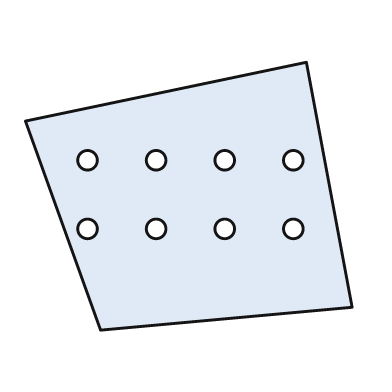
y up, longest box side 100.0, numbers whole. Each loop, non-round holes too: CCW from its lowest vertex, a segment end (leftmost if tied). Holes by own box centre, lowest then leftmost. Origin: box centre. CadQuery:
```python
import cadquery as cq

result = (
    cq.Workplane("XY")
    .moveTo(-27.0, -41.0)
    .lineTo(50.0, -34.0)
    .lineTo(36.0, 41.0)
    .lineTo(-50.0, 23.0)
    .close()
    .moveTo(-31.0, -10.0)
    .circle(3.0)
    .moveTo(-10.0, -10.0)
    .circle(3.0)
    .moveTo(11.0, -10.0)
    .circle(3.0)
    .moveTo(32.0, -10.0)
    .circle(3.0)
    .moveTo(-31.0, 11.0)
    .circle(3.0)
    .moveTo(-10.0, 11.0)
    .circle(3.0)
    .moveTo(11.0, 11.0)
    .circle(3.0)
    .moveTo(32.0, 11.0)
    .circle(3.0)
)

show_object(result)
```